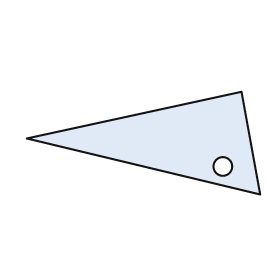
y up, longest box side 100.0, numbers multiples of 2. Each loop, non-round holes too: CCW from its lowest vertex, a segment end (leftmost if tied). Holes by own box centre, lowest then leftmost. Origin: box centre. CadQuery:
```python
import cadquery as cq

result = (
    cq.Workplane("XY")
    .moveTo(50.0, -22.0)
    .lineTo(42.0, 22.0)
    .lineTo(-50.0, 2.0)
    .close()
    .moveTo(34.0, -10.0)
    .circle(4.0)
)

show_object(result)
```